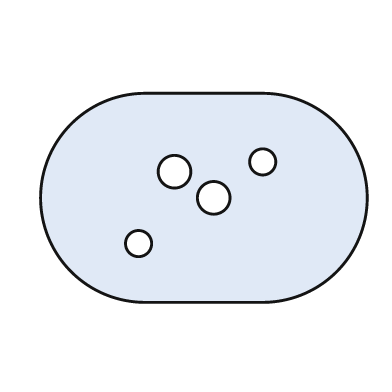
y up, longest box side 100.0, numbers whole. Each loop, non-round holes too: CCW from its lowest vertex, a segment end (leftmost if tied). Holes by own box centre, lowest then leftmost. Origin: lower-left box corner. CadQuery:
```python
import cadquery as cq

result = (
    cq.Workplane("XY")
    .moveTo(32.0, 0.0)
    .lineTo(68.0, 0.0)
    .threePointArc((100.0, 32.0), (68.0, 64.0))
    .lineTo(32.0, 64.0)
    .threePointArc((0.0, 32.0), (32.0, 0.0))
    .close()
    .moveTo(30.0, 18.0)
    .circle(4.0)
    .moveTo(53.0, 32.0)
    .circle(5.0)
    .moveTo(41.0, 40.0)
    .circle(5.0)
    .moveTo(68.0, 43.0)
    .circle(4.0)
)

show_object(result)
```